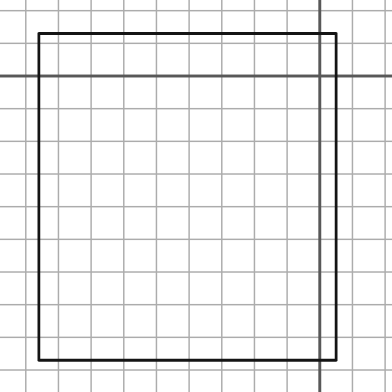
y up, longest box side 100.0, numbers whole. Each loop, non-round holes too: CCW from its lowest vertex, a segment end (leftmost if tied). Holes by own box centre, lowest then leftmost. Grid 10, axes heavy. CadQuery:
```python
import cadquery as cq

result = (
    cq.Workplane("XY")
    .moveTo(-86.0, -87.0)
    .lineTo(5.0, -87.0)
    .lineTo(5.0, 13.0)
    .lineTo(-86.0, 13.0)
    .close()
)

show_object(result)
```